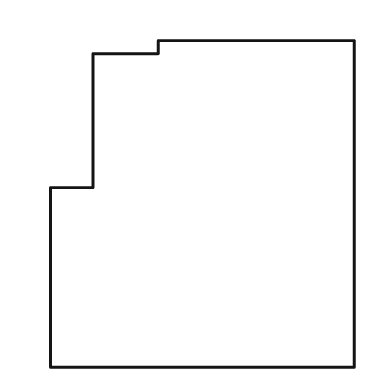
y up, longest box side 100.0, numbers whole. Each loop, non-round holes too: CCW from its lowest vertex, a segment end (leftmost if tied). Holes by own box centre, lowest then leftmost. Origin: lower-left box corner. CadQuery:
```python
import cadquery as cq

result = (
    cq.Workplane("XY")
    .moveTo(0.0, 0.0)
    .lineTo(93.0, 0.0)
    .lineTo(93.0, 100.0)
    .lineTo(33.0, 100.0)
    .lineTo(33.0, 96.0)
    .lineTo(13.0, 96.0)
    .lineTo(13.0, 55.0)
    .lineTo(0.0, 55.0)
    .close()
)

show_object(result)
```